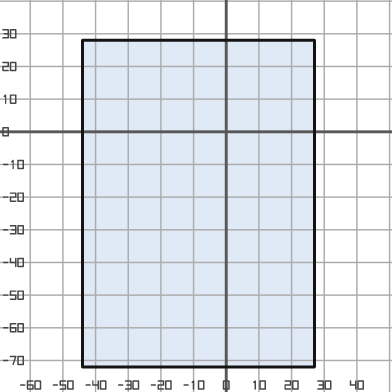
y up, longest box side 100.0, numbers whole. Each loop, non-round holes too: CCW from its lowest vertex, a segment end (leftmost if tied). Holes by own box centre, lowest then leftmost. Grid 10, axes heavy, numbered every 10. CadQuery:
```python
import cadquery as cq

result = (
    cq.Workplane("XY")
    .moveTo(-44.0, -72.0)
    .lineTo(27.0, -72.0)
    .lineTo(27.0, 28.0)
    .lineTo(-44.0, 28.0)
    .close()
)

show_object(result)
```